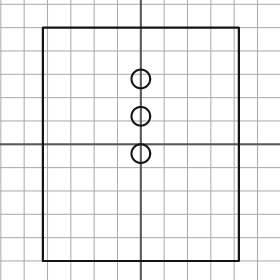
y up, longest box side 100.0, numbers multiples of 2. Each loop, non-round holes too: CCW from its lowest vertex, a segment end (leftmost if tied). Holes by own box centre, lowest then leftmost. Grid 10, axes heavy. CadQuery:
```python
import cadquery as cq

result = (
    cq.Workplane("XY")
    .moveTo(-42.0, -50.0)
    .lineTo(42.0, -50.0)
    .lineTo(42.0, 50.0)
    .lineTo(-42.0, 50.0)
    .close()
    .moveTo(0.0, -4.0)
    .circle(4.0)
    .moveTo(0.0, 12.0)
    .circle(4.0)
    .moveTo(0.0, 28.0)
    .circle(4.0)
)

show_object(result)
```